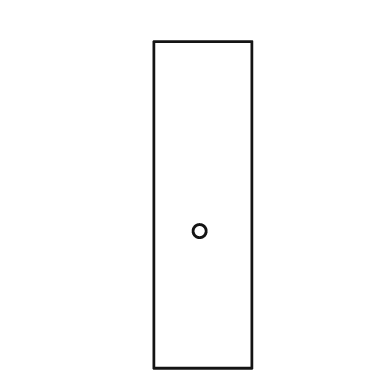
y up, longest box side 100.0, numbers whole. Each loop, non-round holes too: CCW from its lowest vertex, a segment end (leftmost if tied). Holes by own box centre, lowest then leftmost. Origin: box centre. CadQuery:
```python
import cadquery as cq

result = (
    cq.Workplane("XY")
    .moveTo(-15.0, -50.0)
    .lineTo(15.0, -50.0)
    .lineTo(15.0, 50.0)
    .lineTo(-15.0, 50.0)
    .close()
    .moveTo(-1.0, -8.0)
    .circle(2.0)
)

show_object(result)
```